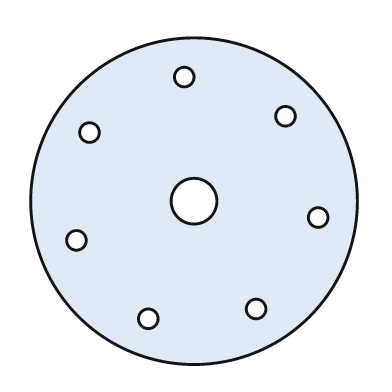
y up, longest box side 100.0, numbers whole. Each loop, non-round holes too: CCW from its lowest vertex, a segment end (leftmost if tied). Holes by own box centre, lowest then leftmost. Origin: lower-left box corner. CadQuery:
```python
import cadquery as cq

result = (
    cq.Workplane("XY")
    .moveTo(50.0, 50.0)
    .circle(50.0)
    .moveTo(36.0, 14.0)
    .circle(3.0)
    .moveTo(69.0, 17.0)
    .circle(3.0)
    .moveTo(14.0, 38.0)
    .circle(3.0)
    .moveTo(88.0, 45.0)
    .circle(3.0)
    .moveTo(50.0, 50.0)
    .circle(7.0)
    .moveTo(18.0, 71.0)
    .circle(3.0)
    .moveTo(78.0, 76.0)
    .circle(3.0)
    .moveTo(47.0, 88.0)
    .circle(3.0)
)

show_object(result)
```